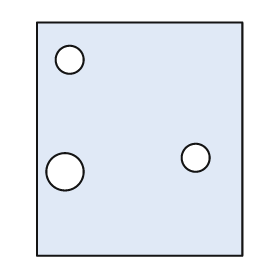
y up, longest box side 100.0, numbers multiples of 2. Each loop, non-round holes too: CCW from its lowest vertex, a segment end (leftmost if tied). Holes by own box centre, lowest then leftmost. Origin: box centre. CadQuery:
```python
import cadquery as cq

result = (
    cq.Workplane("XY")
    .moveTo(-44.0, -50.0)
    .lineTo(44.0, -50.0)
    .lineTo(44.0, 50.0)
    .lineTo(-44.0, 50.0)
    .close()
    .moveTo(-32.0, -14.0)
    .circle(8.0)
    .moveTo(24.0, -8.0)
    .circle(6.0)
    .moveTo(-30.0, 34.0)
    .circle(6.0)
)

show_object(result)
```